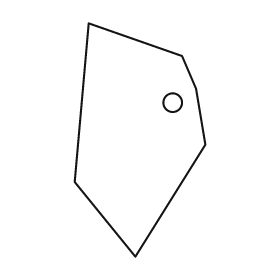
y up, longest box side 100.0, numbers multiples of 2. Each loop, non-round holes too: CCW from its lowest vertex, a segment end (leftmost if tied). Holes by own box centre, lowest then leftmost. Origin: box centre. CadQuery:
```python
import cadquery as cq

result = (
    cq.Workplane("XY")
    .moveTo(-2.0, -50.0)
    .lineTo(28.0, -2.0)
    .lineTo(24.0, 22.0)
    .lineTo(18.0, 36.0)
    .lineTo(-22.0, 50.0)
    .lineTo(-28.0, -18.0)
    .close()
    .moveTo(14.0, 16.0)
    .circle(4.0)
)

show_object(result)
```